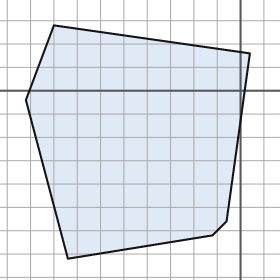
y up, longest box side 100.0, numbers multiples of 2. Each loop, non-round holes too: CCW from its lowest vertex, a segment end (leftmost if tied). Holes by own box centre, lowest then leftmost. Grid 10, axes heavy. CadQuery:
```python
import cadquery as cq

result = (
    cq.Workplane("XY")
    .moveTo(-74.0, -72.0)
    .lineTo(-12.0, -62.0)
    .lineTo(-6.0, -56.0)
    .lineTo(4.0, 16.0)
    .lineTo(-80.0, 28.0)
    .lineTo(-92.0, -4.0)
    .close()
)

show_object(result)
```